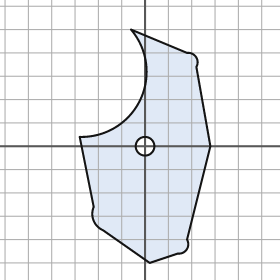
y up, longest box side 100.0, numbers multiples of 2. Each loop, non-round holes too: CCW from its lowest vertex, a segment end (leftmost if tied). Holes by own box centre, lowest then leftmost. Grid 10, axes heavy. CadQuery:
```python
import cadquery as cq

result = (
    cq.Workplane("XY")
    .moveTo(2.0, -50.0)
    .lineTo(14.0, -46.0)
    .threePointArc((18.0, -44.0), (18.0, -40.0))
    .lineTo(28.0, 0.0)
    .lineTo(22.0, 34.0)
    .threePointArc((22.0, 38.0), (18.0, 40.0))
    .lineTo(-6.0, 50.0)
    .threePointArc((-2.0, 20.0), (-28.0, 4.0))
    .lineTo(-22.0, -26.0)
    .threePointArc((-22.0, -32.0), (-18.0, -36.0))
    .close()
    .moveTo(0.0, 0.0)
    .circle(4.0)
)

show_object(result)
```